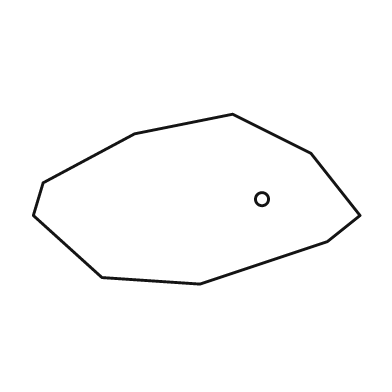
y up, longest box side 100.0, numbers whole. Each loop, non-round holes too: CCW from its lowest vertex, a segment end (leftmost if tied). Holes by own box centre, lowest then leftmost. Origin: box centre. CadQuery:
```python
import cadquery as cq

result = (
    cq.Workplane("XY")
    .moveTo(1.0, -26.0)
    .lineTo(40.0, -13.0)
    .lineTo(50.0, -5.0)
    .lineTo(35.0, 14.0)
    .lineTo(11.0, 26.0)
    .lineTo(-19.0, 20.0)
    .lineTo(-47.0, 5.0)
    .lineTo(-50.0, -5.0)
    .lineTo(-29.0, -24.0)
    .close()
    .moveTo(20.0, 0.0)
    .circle(2.0)
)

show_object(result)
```